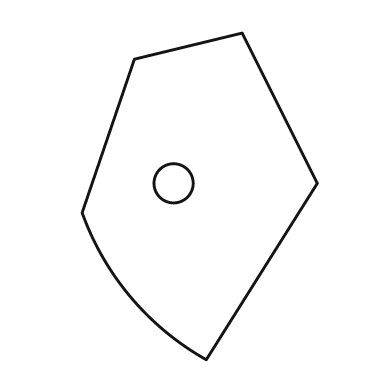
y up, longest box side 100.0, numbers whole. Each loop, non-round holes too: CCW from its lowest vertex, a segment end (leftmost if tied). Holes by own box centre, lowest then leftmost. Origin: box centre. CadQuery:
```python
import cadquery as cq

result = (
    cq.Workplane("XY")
    .moveTo(2.0, -50.0)
    .lineTo(36.0, 4.0)
    .lineTo(13.0, 50.0)
    .lineTo(-20.0, 42.0)
    .lineTo(-36.0, -5.0)
    .threePointArc((-21.0, -31.0), (2.0, -50.0))
    .close()
    .moveTo(-8.0, 4.0)
    .circle(6.0)
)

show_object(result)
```